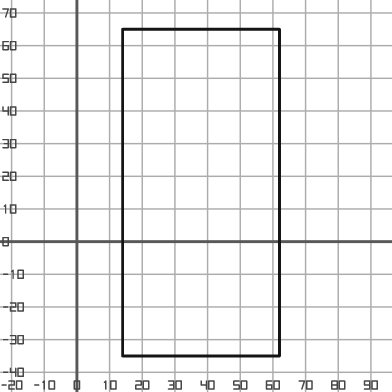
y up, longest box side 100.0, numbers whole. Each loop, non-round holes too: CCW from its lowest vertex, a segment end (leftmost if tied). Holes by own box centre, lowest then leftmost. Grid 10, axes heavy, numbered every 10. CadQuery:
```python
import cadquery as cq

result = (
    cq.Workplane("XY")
    .moveTo(14.0, -35.0)
    .lineTo(62.0, -35.0)
    .lineTo(62.0, 65.0)
    .lineTo(14.0, 65.0)
    .close()
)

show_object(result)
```